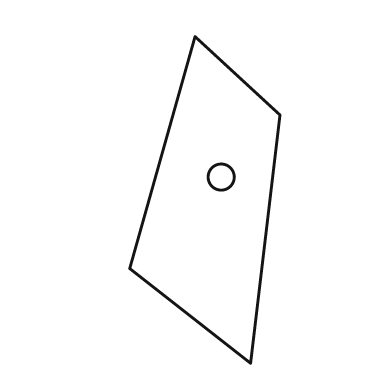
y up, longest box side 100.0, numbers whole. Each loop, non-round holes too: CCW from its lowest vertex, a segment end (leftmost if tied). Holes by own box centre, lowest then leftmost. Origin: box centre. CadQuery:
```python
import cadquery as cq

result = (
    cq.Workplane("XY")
    .moveTo(14.0, -50.0)
    .lineTo(23.0, 26.0)
    .lineTo(-3.0, 50.0)
    .lineTo(-23.0, -21.0)
    .close()
    .moveTo(5.0, 7.0)
    .circle(4.0)
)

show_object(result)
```